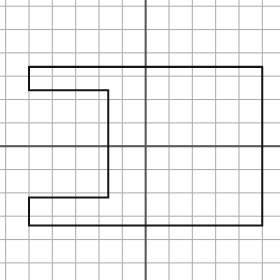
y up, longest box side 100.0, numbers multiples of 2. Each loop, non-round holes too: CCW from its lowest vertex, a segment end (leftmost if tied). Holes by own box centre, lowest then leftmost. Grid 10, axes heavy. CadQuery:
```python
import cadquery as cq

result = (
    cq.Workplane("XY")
    .moveTo(-50.0, -34.0)
    .lineTo(50.0, -34.0)
    .lineTo(50.0, 34.0)
    .lineTo(-50.0, 34.0)
    .lineTo(-50.0, 24.0)
    .lineTo(-16.0, 24.0)
    .lineTo(-16.0, -22.0)
    .lineTo(-50.0, -22.0)
    .close()
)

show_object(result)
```